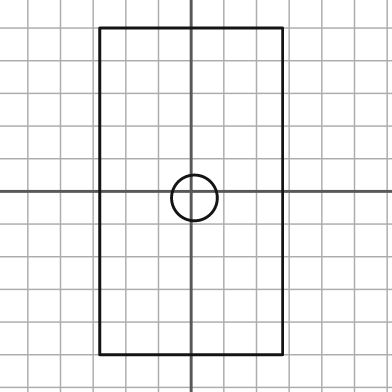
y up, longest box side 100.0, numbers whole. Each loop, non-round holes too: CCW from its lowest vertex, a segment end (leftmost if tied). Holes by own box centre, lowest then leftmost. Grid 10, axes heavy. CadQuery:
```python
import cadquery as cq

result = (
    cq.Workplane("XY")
    .moveTo(-28.0, -50.0)
    .lineTo(28.0, -50.0)
    .lineTo(28.0, 50.0)
    .lineTo(-28.0, 50.0)
    .close()
    .moveTo(1.0, -2.0)
    .circle(7.0)
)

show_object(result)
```